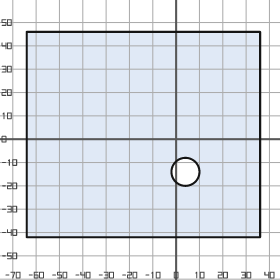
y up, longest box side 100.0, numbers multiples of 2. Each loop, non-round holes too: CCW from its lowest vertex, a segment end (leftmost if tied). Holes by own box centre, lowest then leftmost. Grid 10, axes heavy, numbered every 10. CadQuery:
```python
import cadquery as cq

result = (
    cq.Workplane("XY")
    .moveTo(-64.0, -42.0)
    .lineTo(36.0, -42.0)
    .lineTo(36.0, 46.0)
    .lineTo(-64.0, 46.0)
    .close()
    .moveTo(4.0, -14.0)
    .circle(6.0)
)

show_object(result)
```